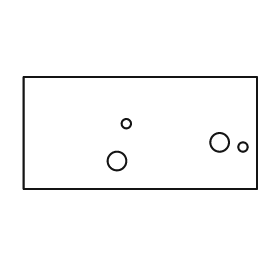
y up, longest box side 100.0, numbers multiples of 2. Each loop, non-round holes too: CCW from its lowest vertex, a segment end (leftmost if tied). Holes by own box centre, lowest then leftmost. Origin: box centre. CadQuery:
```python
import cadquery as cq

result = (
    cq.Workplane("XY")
    .moveTo(-50.0, -24.0)
    .lineTo(50.0, -24.0)
    .lineTo(50.0, 24.0)
    .lineTo(-50.0, 24.0)
    .close()
    .moveTo(-10.0, -12.0)
    .circle(4.0)
    .moveTo(44.0, -6.0)
    .circle(2.0)
    .moveTo(34.0, -4.0)
    .circle(4.0)
    .moveTo(-6.0, 4.0)
    .circle(2.0)
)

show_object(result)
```